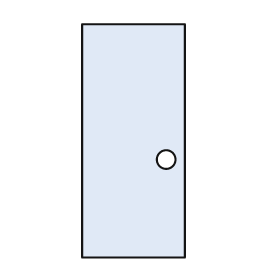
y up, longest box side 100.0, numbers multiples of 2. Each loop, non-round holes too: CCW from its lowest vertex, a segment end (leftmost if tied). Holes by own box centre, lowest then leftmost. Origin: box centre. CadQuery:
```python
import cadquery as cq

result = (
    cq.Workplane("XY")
    .moveTo(-22.0, -50.0)
    .lineTo(22.0, -50.0)
    .lineTo(22.0, 50.0)
    .lineTo(-22.0, 50.0)
    .close()
    .moveTo(14.0, -8.0)
    .circle(4.0)
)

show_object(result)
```